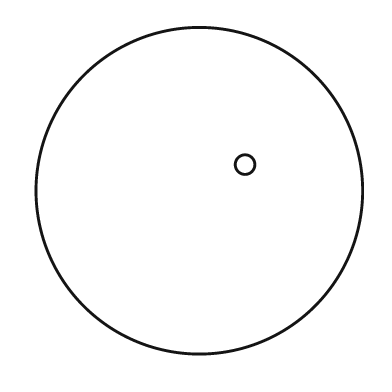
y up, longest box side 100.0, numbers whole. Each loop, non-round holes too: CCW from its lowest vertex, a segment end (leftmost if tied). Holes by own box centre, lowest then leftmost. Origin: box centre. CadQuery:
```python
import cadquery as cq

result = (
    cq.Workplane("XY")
    .moveTo(0.0, 0.0)
    .circle(50.0)
    .moveTo(14.0, 8.0)
    .circle(3.0)
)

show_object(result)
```